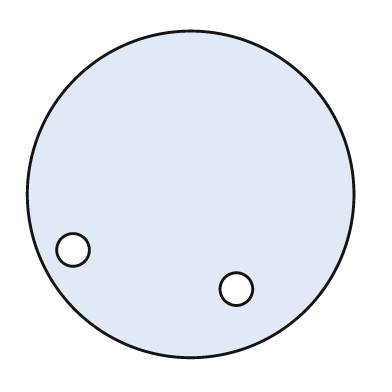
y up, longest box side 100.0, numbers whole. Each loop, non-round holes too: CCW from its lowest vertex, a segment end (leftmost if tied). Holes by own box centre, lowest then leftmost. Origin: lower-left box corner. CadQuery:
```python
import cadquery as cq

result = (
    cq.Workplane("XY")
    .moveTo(50.0, 50.0)
    .circle(50.0)
    .moveTo(64.0, 21.0)
    .circle(5.0)
    .moveTo(14.0, 33.0)
    .circle(5.0)
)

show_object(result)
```